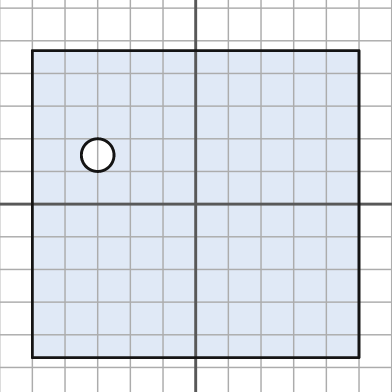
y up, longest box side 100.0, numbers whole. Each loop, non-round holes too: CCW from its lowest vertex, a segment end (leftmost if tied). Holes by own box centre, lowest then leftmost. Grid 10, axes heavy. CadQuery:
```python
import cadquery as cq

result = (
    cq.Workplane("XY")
    .moveTo(-50.0, -47.0)
    .lineTo(50.0, -47.0)
    .lineTo(50.0, 47.0)
    .lineTo(-50.0, 47.0)
    .close()
    .moveTo(-30.0, 15.0)
    .circle(5.0)
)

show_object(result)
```